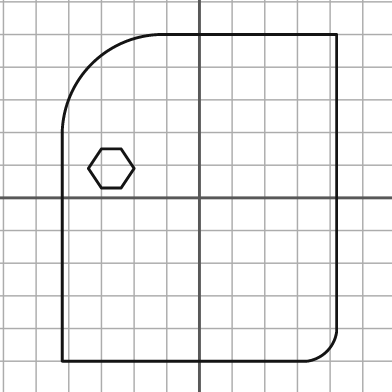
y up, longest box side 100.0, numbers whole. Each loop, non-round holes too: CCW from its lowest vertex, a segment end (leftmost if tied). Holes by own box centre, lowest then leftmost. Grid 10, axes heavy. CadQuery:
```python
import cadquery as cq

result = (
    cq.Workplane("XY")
    .moveTo(-42.0, -50.0)
    .lineTo(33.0, -50.0)
    .threePointArc((39.0, -47.0), (42.0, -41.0))
    .lineTo(42.0, 50.0)
    .lineTo(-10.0, 50.0)
    .threePointArc((-33.0, 41.0), (-42.0, 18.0))
    .close()
    .moveTo(-30.0, 3.0)
    .lineTo(-24.0, 3.0)
    .lineTo(-20.0, 9.0)
    .lineTo(-24.0, 15.0)
    .lineTo(-30.0, 15.0)
    .lineTo(-34.0, 9.0)
    .close()
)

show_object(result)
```